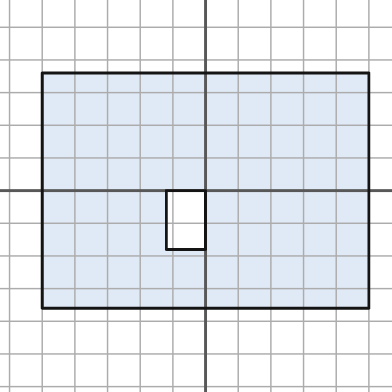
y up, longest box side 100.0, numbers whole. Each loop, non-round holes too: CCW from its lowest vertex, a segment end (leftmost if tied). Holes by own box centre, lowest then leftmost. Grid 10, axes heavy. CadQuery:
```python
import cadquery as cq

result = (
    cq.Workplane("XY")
    .moveTo(-50.0, -36.0)
    .lineTo(50.0, -36.0)
    .lineTo(50.0, 36.0)
    .lineTo(-50.0, 36.0)
    .close()
    .moveTo(-12.0, -18.0)
    .lineTo(0.0, -18.0)
    .lineTo(0.0, 0.0)
    .lineTo(-12.0, 0.0)
    .close()
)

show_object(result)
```